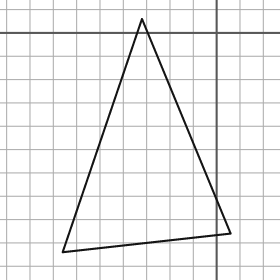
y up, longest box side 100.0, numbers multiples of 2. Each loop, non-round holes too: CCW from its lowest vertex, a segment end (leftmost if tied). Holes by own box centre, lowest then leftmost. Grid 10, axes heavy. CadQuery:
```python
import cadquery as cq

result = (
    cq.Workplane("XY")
    .moveTo(-66.0, -94.0)
    .lineTo(6.0, -86.0)
    .lineTo(-32.0, 6.0)
    .close()
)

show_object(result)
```